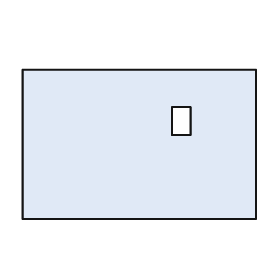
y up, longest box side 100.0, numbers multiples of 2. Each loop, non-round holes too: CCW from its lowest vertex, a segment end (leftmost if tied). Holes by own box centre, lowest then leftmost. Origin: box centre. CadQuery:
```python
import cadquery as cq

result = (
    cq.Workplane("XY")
    .moveTo(-50.0, -32.0)
    .lineTo(50.0, -32.0)
    .lineTo(50.0, 32.0)
    .lineTo(-50.0, 32.0)
    .close()
    .moveTo(14.0, 4.0)
    .lineTo(22.0, 4.0)
    .lineTo(22.0, 16.0)
    .lineTo(14.0, 16.0)
    .close()
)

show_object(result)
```